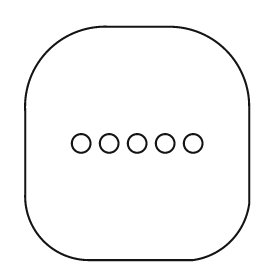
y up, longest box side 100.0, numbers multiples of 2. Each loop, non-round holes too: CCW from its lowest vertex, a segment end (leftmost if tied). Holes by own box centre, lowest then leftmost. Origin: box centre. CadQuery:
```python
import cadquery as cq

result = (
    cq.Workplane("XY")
    .moveTo(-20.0, -50.0)
    .lineTo(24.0, -50.0)
    .threePointArc((40.0, -42.0), (48.0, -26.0))
    .lineTo(48.0, 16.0)
    .threePointArc((38.0, 40.0), (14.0, 50.0))
    .lineTo(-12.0, 50.0)
    .threePointArc((-38.0, 40.0), (-48.0, 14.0))
    .lineTo(-48.0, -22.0)
    .threePointArc((-40.0, -42.0), (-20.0, -50.0))
    .close()
    .moveTo(-24.0, 0.0)
    .circle(4.0)
    .moveTo(-12.0, 0.0)
    .circle(4.0)
    .moveTo(0.0, 0.0)
    .circle(4.0)
    .moveTo(12.0, 0.0)
    .circle(4.0)
    .moveTo(24.0, 0.0)
    .circle(4.0)
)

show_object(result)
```